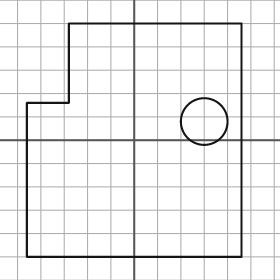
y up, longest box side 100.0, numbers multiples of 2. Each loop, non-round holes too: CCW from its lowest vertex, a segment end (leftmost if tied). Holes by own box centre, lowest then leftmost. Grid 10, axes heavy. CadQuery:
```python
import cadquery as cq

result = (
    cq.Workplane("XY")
    .moveTo(-46.0, -50.0)
    .lineTo(46.0, -50.0)
    .lineTo(46.0, 50.0)
    .lineTo(-28.0, 50.0)
    .lineTo(-28.0, 16.0)
    .lineTo(-46.0, 16.0)
    .close()
    .moveTo(30.0, 8.0)
    .circle(10.0)
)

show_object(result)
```